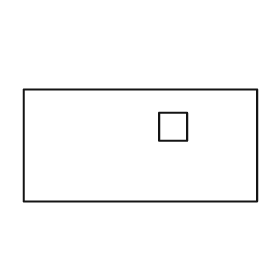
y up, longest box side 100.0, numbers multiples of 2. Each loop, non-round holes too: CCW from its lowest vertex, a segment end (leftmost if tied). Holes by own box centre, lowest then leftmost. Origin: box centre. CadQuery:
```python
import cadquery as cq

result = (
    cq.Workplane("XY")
    .moveTo(-50.0, -24.0)
    .lineTo(50.0, -24.0)
    .lineTo(50.0, 24.0)
    .lineTo(-50.0, 24.0)
    .close()
    .moveTo(8.0, 2.0)
    .lineTo(20.0, 2.0)
    .lineTo(20.0, 14.0)
    .lineTo(8.0, 14.0)
    .close()
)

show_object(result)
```